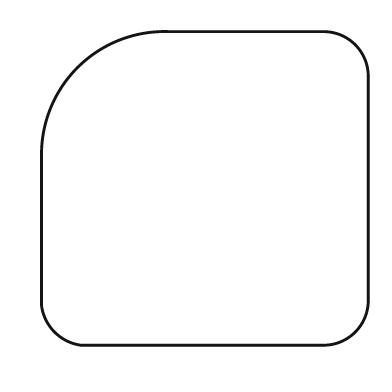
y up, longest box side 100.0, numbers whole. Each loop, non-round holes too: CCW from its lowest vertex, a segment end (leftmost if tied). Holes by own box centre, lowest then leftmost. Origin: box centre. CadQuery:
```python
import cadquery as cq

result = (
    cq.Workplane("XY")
    .moveTo(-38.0, -48.0)
    .lineTo(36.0, -48.0)
    .threePointArc((46.0, -44.0), (50.0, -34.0))
    .lineTo(50.0, 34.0)
    .threePointArc((46.0, 44.0), (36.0, 48.0))
    .lineTo(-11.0, 48.0)
    .threePointArc((-39.0, 37.0), (-50.0, 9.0))
    .lineTo(-50.0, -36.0)
    .threePointArc((-46.0, -44.0), (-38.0, -48.0))
    .close()
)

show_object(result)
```